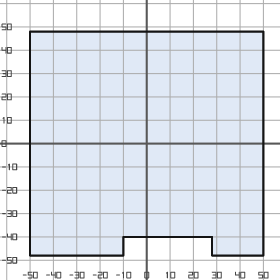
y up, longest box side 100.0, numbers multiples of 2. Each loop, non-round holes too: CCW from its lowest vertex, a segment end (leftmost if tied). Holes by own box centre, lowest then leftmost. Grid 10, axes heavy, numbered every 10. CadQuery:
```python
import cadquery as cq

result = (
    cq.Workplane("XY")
    .moveTo(-50.0, -48.0)
    .lineTo(-10.0, -48.0)
    .lineTo(-10.0, -40.0)
    .lineTo(28.0, -40.0)
    .lineTo(28.0, -48.0)
    .lineTo(50.0, -48.0)
    .lineTo(50.0, 48.0)
    .lineTo(-50.0, 48.0)
    .close()
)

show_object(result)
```